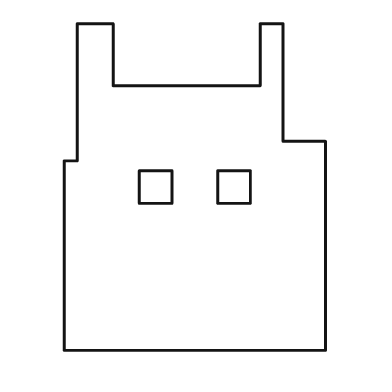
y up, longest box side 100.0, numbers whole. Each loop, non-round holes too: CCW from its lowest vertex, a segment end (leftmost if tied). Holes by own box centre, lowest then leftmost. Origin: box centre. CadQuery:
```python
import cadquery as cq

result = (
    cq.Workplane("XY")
    .moveTo(-40.0, -50.0)
    .lineTo(40.0, -50.0)
    .lineTo(40.0, 14.0)
    .lineTo(27.0, 14.0)
    .lineTo(27.0, 50.0)
    .lineTo(20.0, 50.0)
    .lineTo(20.0, 31.0)
    .lineTo(-25.0, 31.0)
    .lineTo(-25.0, 50.0)
    .lineTo(-36.0, 50.0)
    .lineTo(-36.0, 8.0)
    .lineTo(-40.0, 8.0)
    .close()
    .moveTo(-17.0, -5.0)
    .lineTo(-7.0, -5.0)
    .lineTo(-7.0, 5.0)
    .lineTo(-17.0, 5.0)
    .close()
    .moveTo(7.0, -5.0)
    .lineTo(17.0, -5.0)
    .lineTo(17.0, 5.0)
    .lineTo(7.0, 5.0)
    .close()
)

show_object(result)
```